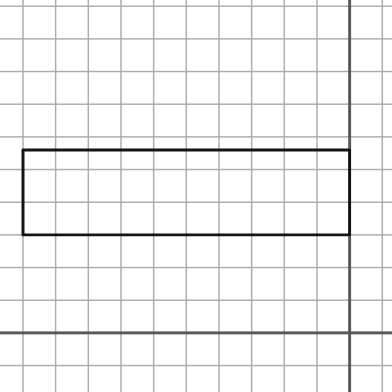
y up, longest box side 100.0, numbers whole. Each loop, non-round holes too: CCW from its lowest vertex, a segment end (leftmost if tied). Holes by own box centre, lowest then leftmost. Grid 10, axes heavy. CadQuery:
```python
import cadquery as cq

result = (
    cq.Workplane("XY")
    .moveTo(-100.0, 30.0)
    .lineTo(0.0, 30.0)
    .lineTo(0.0, 56.0)
    .lineTo(-100.0, 56.0)
    .close()
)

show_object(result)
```